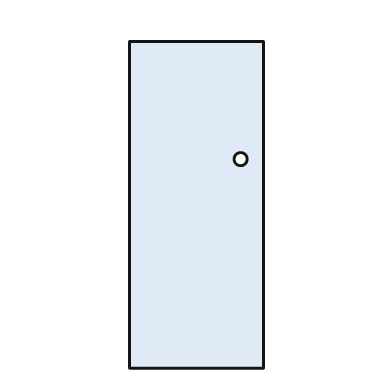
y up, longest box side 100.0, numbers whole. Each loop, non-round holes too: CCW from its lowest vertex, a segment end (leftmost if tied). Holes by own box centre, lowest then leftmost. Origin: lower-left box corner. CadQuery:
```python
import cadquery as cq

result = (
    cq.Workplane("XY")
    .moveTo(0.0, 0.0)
    .lineTo(41.0, 0.0)
    .lineTo(41.0, 100.0)
    .lineTo(0.0, 100.0)
    .close()
    .moveTo(34.0, 64.0)
    .circle(2.0)
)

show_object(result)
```